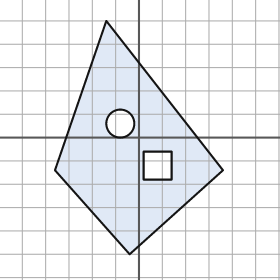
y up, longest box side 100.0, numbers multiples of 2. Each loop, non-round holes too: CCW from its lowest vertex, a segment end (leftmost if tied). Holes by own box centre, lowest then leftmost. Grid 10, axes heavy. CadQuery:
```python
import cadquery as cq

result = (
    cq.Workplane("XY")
    .moveTo(-4.0, -50.0)
    .lineTo(36.0, -14.0)
    .lineTo(-14.0, 50.0)
    .lineTo(-36.0, -14.0)
    .close()
    .moveTo(2.0, -18.0)
    .lineTo(14.0, -18.0)
    .lineTo(14.0, -6.0)
    .lineTo(2.0, -6.0)
    .close()
    .moveTo(-8.0, 6.0)
    .circle(6.0)
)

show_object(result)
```